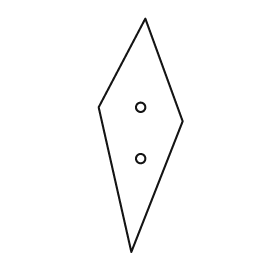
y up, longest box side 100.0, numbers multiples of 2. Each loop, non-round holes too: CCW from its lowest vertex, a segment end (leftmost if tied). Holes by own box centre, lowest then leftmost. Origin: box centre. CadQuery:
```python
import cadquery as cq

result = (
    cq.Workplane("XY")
    .moveTo(-4.0, -50.0)
    .lineTo(18.0, 6.0)
    .lineTo(2.0, 50.0)
    .lineTo(-18.0, 12.0)
    .close()
    .moveTo(0.0, -10.0)
    .circle(2.0)
    .moveTo(0.0, 12.0)
    .circle(2.0)
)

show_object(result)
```